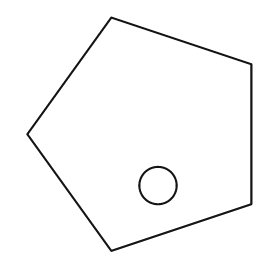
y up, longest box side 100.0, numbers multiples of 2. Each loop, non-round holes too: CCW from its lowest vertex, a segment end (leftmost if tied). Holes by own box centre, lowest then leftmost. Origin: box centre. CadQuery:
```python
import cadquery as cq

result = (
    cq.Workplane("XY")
    .moveTo(-12.0, -50.0)
    .lineTo(48.0, -30.0)
    .lineTo(48.0, 30.0)
    .lineTo(-12.0, 50.0)
    .lineTo(-48.0, 0.0)
    .close()
    .moveTo(8.0, -22.0)
    .circle(8.0)
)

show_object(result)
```